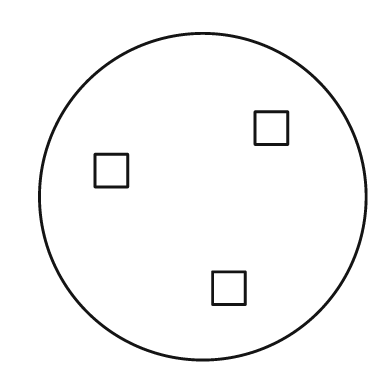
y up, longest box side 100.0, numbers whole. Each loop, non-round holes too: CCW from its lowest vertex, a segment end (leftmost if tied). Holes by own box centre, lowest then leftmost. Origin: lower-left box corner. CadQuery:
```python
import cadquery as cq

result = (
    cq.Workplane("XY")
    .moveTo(50.0, 50.0)
    .circle(50.0)
    .moveTo(53.0, 17.0)
    .lineTo(63.0, 17.0)
    .lineTo(63.0, 27.0)
    .lineTo(53.0, 27.0)
    .close()
    .moveTo(17.0, 53.0)
    .lineTo(27.0, 53.0)
    .lineTo(27.0, 63.0)
    .lineTo(17.0, 63.0)
    .close()
    .moveTo(66.0, 66.0)
    .lineTo(76.0, 66.0)
    .lineTo(76.0, 76.0)
    .lineTo(66.0, 76.0)
    .close()
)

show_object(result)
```